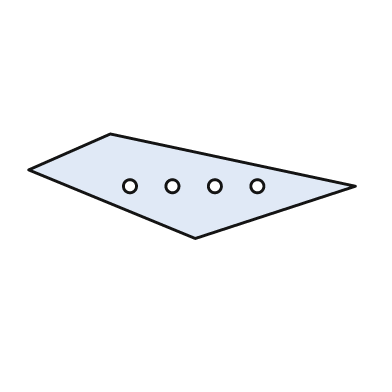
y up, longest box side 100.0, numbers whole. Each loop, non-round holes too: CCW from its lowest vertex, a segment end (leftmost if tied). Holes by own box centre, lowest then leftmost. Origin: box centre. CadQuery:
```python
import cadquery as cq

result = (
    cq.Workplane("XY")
    .moveTo(1.0, -16.0)
    .lineTo(50.0, 0.0)
    .lineTo(-25.0, 16.0)
    .lineTo(-50.0, 5.0)
    .close()
    .moveTo(-19.0, 0.0)
    .circle(2.0)
    .moveTo(-6.0, 0.0)
    .circle(2.0)
    .moveTo(7.0, 0.0)
    .circle(2.0)
    .moveTo(20.0, 0.0)
    .circle(2.0)
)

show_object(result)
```